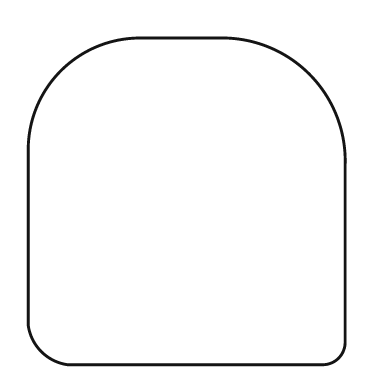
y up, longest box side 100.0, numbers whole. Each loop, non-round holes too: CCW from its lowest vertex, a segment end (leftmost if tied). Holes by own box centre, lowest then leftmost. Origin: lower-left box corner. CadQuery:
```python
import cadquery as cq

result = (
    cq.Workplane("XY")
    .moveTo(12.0, 0.0)
    .lineTo(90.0, 0.0)
    .threePointArc((95.0, 2.0), (97.0, 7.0))
    .lineTo(97.0, 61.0)
    .threePointArc((86.0, 89.0), (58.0, 100.0))
    .lineTo(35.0, 100.0)
    .threePointArc((10.0, 90.0), (0.0, 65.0))
    .lineTo(0.0, 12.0)
    .threePointArc((4.0, 4.0), (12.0, 0.0))
    .close()
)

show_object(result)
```